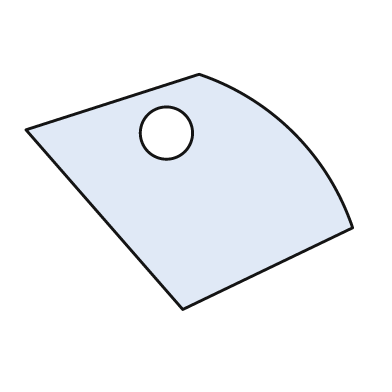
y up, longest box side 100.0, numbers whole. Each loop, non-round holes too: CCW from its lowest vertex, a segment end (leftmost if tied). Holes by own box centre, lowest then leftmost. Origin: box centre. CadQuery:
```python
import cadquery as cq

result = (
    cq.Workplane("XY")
    .moveTo(-2.0, -36.0)
    .lineTo(50.0, -11.0)
    .threePointArc((32.0, 18.0), (3.0, 36.0))
    .lineTo(-50.0, 19.0)
    .close()
    .moveTo(-7.0, 18.0)
    .circle(8.0)
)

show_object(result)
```